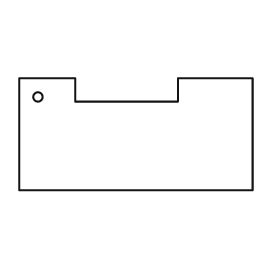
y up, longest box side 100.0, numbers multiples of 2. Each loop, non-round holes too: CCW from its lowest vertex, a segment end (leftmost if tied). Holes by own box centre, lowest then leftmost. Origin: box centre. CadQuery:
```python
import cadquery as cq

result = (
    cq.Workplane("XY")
    .moveTo(-50.0, -24.0)
    .lineTo(50.0, -24.0)
    .lineTo(50.0, 24.0)
    .lineTo(18.0, 24.0)
    .lineTo(18.0, 14.0)
    .lineTo(-26.0, 14.0)
    .lineTo(-26.0, 24.0)
    .lineTo(-50.0, 24.0)
    .close()
    .moveTo(-42.0, 16.0)
    .circle(2.0)
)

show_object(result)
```